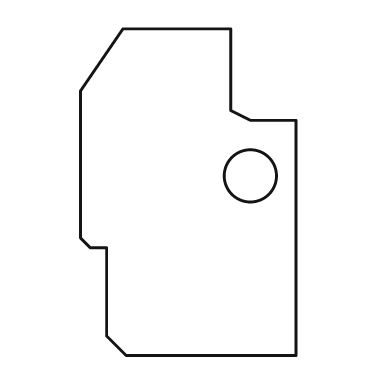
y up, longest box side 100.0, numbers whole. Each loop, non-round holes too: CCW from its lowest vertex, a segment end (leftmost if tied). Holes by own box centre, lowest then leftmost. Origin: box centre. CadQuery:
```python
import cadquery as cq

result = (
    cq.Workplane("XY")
    .moveTo(-19.0, -50.0)
    .lineTo(33.0, -50.0)
    .lineTo(33.0, 22.0)
    .lineTo(19.0, 22.0)
    .lineTo(13.0, 25.0)
    .lineTo(13.0, 50.0)
    .lineTo(-20.0, 50.0)
    .lineTo(-33.0, 31.0)
    .lineTo(-33.0, -14.0)
    .lineTo(-30.0, -17.0)
    .lineTo(-25.0, -17.0)
    .lineTo(-25.0, -44.0)
    .close()
    .moveTo(19.0, 5.0)
    .circle(8.0)
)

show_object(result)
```